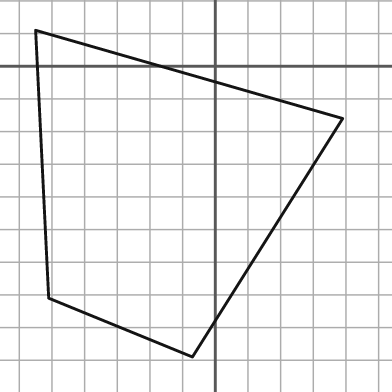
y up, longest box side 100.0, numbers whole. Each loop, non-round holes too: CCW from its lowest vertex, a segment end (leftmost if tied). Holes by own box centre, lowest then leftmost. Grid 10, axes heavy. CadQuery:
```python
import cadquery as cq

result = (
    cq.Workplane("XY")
    .moveTo(-7.0, -89.0)
    .lineTo(39.0, -16.0)
    .lineTo(-55.0, 11.0)
    .lineTo(-51.0, -71.0)
    .close()
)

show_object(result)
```